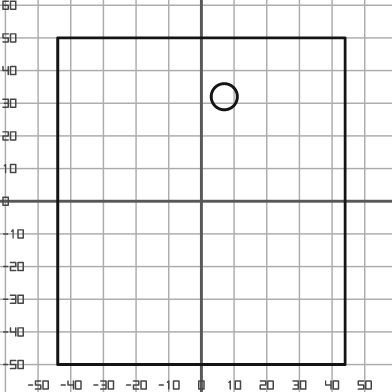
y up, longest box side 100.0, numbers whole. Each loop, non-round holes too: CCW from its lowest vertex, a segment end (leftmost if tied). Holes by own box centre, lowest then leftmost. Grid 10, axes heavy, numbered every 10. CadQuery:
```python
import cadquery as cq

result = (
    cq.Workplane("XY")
    .moveTo(-44.0, -50.0)
    .lineTo(44.0, -50.0)
    .lineTo(44.0, 50.0)
    .lineTo(-44.0, 50.0)
    .close()
    .moveTo(7.0, 32.0)
    .circle(4.0)
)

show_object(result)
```